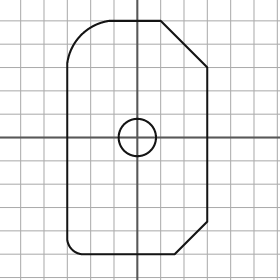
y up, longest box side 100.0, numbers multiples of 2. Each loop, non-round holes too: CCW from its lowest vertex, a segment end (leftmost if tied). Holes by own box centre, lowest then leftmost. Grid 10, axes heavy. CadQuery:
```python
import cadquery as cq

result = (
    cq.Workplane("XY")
    .moveTo(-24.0, -50.0)
    .lineTo(16.0, -50.0)
    .lineTo(30.0, -36.0)
    .lineTo(30.0, 30.0)
    .lineTo(10.0, 50.0)
    .lineTo(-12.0, 50.0)
    .threePointArc((-24.0, 44.0), (-30.0, 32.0))
    .lineTo(-30.0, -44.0)
    .threePointArc((-28.0, -48.0), (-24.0, -50.0))
    .close()
    .moveTo(0.0, 0.0)
    .circle(8.0)
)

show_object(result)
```